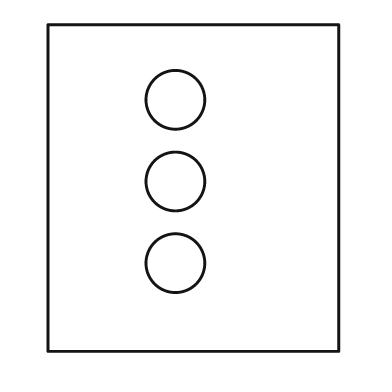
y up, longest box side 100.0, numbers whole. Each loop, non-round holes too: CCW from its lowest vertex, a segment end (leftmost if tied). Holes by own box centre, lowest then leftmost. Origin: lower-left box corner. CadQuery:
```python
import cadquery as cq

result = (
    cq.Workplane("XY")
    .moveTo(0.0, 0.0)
    .lineTo(89.0, 0.0)
    .lineTo(89.0, 100.0)
    .lineTo(0.0, 100.0)
    .close()
    .moveTo(39.0, 27.0)
    .circle(9.0)
    .moveTo(39.0, 52.0)
    .circle(9.0)
    .moveTo(39.0, 77.0)
    .circle(9.0)
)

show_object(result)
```